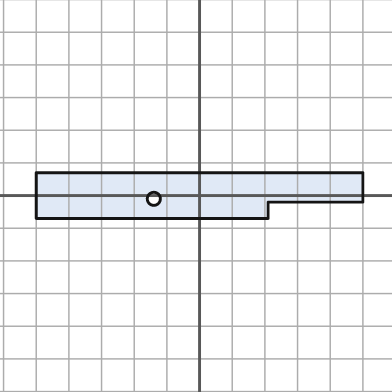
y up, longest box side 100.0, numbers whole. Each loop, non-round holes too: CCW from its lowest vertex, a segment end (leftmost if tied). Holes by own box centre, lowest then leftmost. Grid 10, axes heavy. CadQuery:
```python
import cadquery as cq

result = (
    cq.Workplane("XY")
    .moveTo(-50.0, -7.0)
    .lineTo(21.0, -7.0)
    .lineTo(21.0, -2.0)
    .lineTo(50.0, -2.0)
    .lineTo(50.0, 7.0)
    .lineTo(-50.0, 7.0)
    .close()
    .moveTo(-14.0, -1.0)
    .circle(2.0)
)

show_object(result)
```